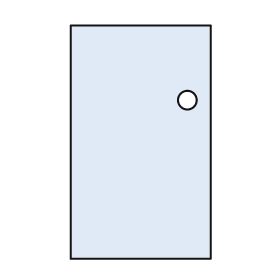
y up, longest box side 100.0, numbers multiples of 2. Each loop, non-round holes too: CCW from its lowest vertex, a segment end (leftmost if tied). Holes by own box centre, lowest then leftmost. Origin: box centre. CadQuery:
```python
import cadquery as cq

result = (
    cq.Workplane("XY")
    .moveTo(-30.0, -50.0)
    .lineTo(30.0, -50.0)
    .lineTo(30.0, 50.0)
    .lineTo(-30.0, 50.0)
    .close()
    .moveTo(20.0, 18.0)
    .circle(4.0)
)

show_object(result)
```